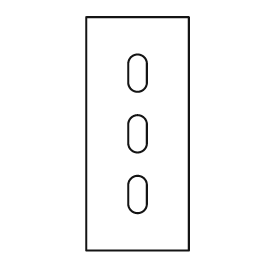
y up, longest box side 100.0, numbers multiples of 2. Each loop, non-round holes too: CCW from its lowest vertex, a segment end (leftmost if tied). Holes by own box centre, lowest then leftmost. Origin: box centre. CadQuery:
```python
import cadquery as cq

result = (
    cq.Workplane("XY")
    .moveTo(-22.0, -50.0)
    .lineTo(22.0, -50.0)
    .lineTo(22.0, 50.0)
    .lineTo(-22.0, 50.0)
    .close()
    .moveTo(-4.0, -30.0)
    .threePointArc((0.0, -34.0), (4.0, -30.0))
    .lineTo(4.0, -22.0)
    .threePointArc((0.0, -18.0), (-4.0, -22.0))
    .close()
    .moveTo(-4.0, -4.0)
    .threePointArc((0.0, -8.0), (4.0, -4.0))
    .lineTo(4.0, 4.0)
    .threePointArc((0.0, 8.0), (-4.0, 4.0))
    .close()
    .moveTo(-4.0, 22.0)
    .threePointArc((0.0, 18.0), (4.0, 22.0))
    .lineTo(4.0, 30.0)
    .threePointArc((0.0, 34.0), (-4.0, 30.0))
    .close()
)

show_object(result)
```